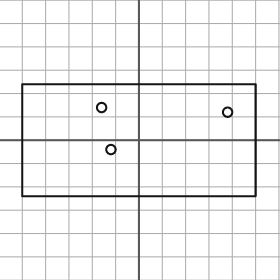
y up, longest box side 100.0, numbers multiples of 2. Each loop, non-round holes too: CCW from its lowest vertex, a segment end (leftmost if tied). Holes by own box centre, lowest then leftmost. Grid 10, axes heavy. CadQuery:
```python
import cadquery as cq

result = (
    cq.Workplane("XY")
    .moveTo(-50.0, -24.0)
    .lineTo(50.0, -24.0)
    .lineTo(50.0, 24.0)
    .lineTo(-50.0, 24.0)
    .close()
    .moveTo(-12.0, -4.0)
    .circle(2.0)
    .moveTo(38.0, 12.0)
    .circle(2.0)
    .moveTo(-16.0, 14.0)
    .circle(2.0)
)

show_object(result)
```